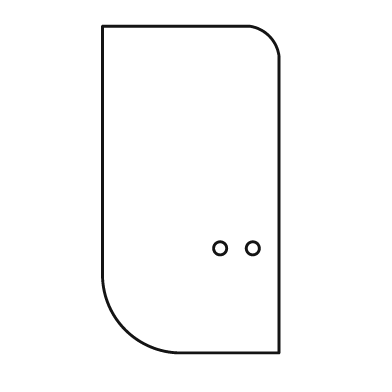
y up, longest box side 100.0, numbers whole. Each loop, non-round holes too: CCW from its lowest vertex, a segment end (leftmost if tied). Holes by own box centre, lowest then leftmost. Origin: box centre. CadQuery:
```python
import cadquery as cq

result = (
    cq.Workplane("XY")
    .moveTo(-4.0, -50.0)
    .lineTo(27.0, -50.0)
    .lineTo(27.0, 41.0)
    .threePointArc((24.0, 47.0), (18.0, 50.0))
    .lineTo(-27.0, 50.0)
    .lineTo(-27.0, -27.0)
    .threePointArc((-20.0, -43.0), (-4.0, -50.0))
    .close()
    .moveTo(9.0, -18.0)
    .circle(2.0)
    .moveTo(19.0, -18.0)
    .circle(2.0)
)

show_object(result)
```